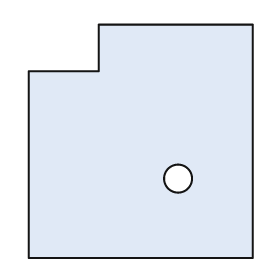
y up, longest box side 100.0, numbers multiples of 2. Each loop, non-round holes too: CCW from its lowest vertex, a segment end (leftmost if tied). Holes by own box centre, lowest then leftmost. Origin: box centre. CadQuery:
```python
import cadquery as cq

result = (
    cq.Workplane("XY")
    .moveTo(-48.0, -50.0)
    .lineTo(48.0, -50.0)
    .lineTo(48.0, 50.0)
    .lineTo(-18.0, 50.0)
    .lineTo(-18.0, 30.0)
    .lineTo(-48.0, 30.0)
    .close()
    .moveTo(16.0, -16.0)
    .circle(6.0)
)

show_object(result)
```